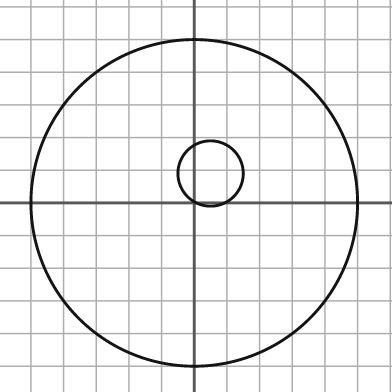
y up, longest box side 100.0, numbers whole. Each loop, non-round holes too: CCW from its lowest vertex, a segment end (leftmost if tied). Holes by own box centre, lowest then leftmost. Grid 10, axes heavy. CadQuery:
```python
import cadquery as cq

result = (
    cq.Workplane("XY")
    .moveTo(0.0, 0.0)
    .circle(50.0)
    .moveTo(5.0, 9.0)
    .circle(10.0)
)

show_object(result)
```